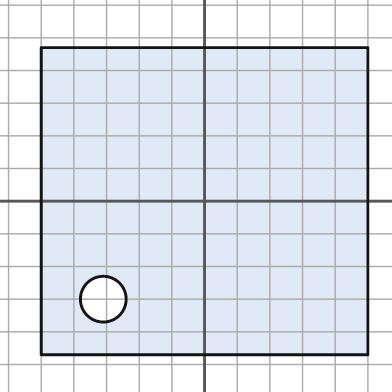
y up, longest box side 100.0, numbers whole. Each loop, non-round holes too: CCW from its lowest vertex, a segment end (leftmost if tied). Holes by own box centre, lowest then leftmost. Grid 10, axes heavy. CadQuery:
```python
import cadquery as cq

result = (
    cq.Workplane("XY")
    .moveTo(-50.0, -47.0)
    .lineTo(50.0, -47.0)
    .lineTo(50.0, 47.0)
    .lineTo(-50.0, 47.0)
    .close()
    .moveTo(-31.0, -30.0)
    .circle(7.0)
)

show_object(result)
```